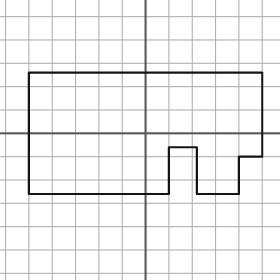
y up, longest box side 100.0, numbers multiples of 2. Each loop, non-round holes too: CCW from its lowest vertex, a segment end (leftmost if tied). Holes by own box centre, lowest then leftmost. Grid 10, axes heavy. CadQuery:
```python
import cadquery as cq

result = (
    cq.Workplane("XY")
    .moveTo(-50.0, -26.0)
    .lineTo(10.0, -26.0)
    .lineTo(10.0, -6.0)
    .lineTo(22.0, -6.0)
    .lineTo(22.0, -26.0)
    .lineTo(40.0, -26.0)
    .lineTo(40.0, -10.0)
    .lineTo(50.0, -10.0)
    .lineTo(50.0, 26.0)
    .lineTo(-50.0, 26.0)
    .close()
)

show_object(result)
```